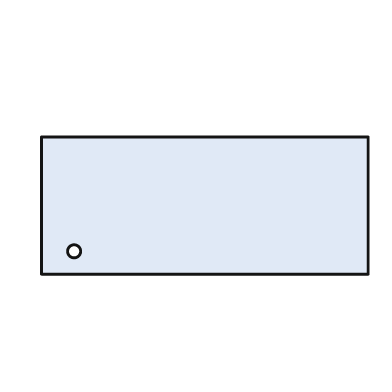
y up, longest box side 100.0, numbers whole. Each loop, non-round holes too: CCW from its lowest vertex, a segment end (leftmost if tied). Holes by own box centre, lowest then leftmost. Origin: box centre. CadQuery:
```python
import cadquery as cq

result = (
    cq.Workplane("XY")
    .moveTo(-50.0, -21.0)
    .lineTo(50.0, -21.0)
    .lineTo(50.0, 21.0)
    .lineTo(-50.0, 21.0)
    .close()
    .moveTo(-40.0, -14.0)
    .circle(2.0)
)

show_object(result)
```